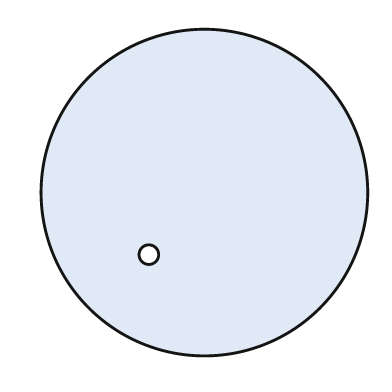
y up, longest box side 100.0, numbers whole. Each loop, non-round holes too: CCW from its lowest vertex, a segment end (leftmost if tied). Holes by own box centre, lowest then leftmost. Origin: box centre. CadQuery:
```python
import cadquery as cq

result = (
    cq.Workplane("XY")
    .moveTo(0.0, 0.0)
    .circle(50.0)
    .moveTo(-17.0, -19.0)
    .circle(3.0)
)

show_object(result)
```